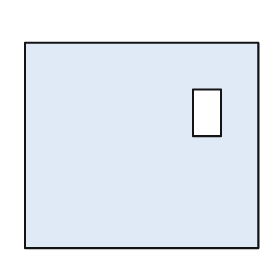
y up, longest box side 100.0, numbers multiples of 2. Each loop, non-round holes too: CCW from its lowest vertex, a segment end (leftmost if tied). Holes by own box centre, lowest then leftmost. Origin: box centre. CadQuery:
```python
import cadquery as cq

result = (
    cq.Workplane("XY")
    .moveTo(-50.0, -44.0)
    .lineTo(50.0, -44.0)
    .lineTo(50.0, 44.0)
    .lineTo(-50.0, 44.0)
    .close()
    .moveTo(22.0, 4.0)
    .lineTo(34.0, 4.0)
    .lineTo(34.0, 24.0)
    .lineTo(22.0, 24.0)
    .close()
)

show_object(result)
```